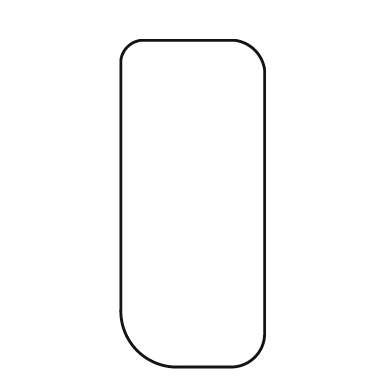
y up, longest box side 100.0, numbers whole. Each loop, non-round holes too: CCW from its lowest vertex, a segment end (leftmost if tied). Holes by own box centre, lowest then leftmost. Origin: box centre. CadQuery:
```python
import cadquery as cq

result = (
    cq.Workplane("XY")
    .moveTo(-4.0, -50.0)
    .lineTo(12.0, -50.0)
    .threePointArc((19.0, -47.0), (22.0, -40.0))
    .lineTo(22.0, 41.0)
    .threePointArc((19.0, 47.0), (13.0, 50.0))
    .lineTo(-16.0, 50.0)
    .threePointArc((-20.0, 48.0), (-22.0, 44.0))
    .lineTo(-22.0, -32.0)
    .threePointArc((-17.0, -45.0), (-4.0, -50.0))
    .close()
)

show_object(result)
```